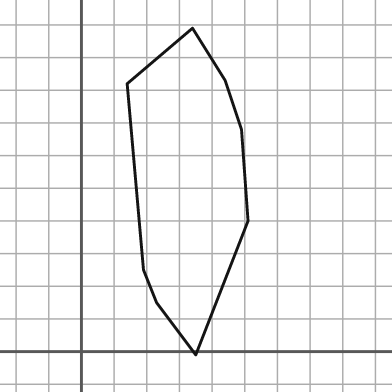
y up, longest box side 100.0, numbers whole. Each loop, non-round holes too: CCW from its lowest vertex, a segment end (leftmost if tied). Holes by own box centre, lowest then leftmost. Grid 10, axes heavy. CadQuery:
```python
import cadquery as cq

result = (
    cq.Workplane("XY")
    .moveTo(35.0, -1.0)
    .lineTo(51.0, 40.0)
    .lineTo(49.0, 68.0)
    .lineTo(44.0, 83.0)
    .lineTo(34.0, 99.0)
    .lineTo(14.0, 82.0)
    .lineTo(19.0, 25.0)
    .lineTo(23.0, 15.0)
    .close()
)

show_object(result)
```